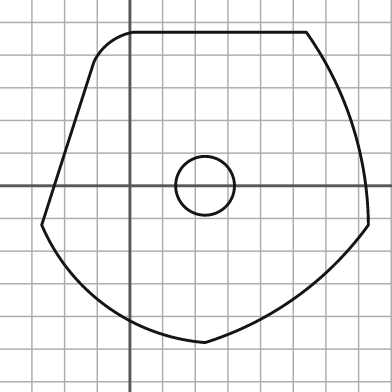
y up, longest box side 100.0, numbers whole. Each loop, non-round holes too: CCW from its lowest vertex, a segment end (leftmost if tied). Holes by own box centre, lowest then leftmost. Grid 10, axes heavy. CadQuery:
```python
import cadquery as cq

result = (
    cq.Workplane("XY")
    .moveTo(23.0, -48.0)
    .threePointArc((51.0, -34.0), (73.0, -12.0))
    .threePointArc((68.0, 19.0), (54.0, 47.0))
    .lineTo(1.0, 47.0)
    .threePointArc((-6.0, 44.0), (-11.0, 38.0))
    .lineTo(-27.0, -12.0)
    .threePointArc((-7.0, -37.0), (23.0, -48.0))
    .close()
    .moveTo(23.0, 0.0)
    .circle(9.0)
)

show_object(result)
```